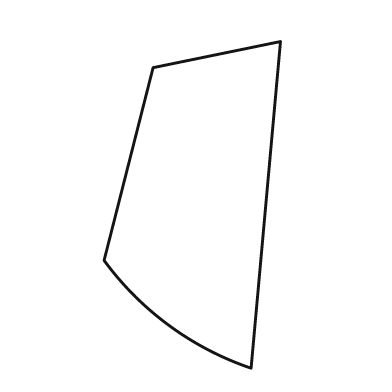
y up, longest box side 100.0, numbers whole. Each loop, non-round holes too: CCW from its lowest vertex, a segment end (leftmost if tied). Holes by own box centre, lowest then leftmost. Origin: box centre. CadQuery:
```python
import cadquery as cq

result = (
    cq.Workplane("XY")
    .moveTo(18.0, -50.0)
    .lineTo(27.0, 50.0)
    .lineTo(-12.0, 42.0)
    .lineTo(-27.0, -17.0)
    .threePointArc((-7.0, -37.0), (18.0, -50.0))
    .close()
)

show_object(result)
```